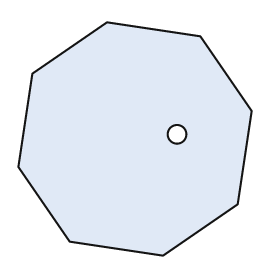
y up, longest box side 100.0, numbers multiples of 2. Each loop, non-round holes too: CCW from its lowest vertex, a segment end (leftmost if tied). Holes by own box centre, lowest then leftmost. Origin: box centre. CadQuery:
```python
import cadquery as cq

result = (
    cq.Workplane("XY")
    .moveTo(12.0, -50.0)
    .lineTo(44.0, -28.0)
    .lineTo(50.0, 12.0)
    .lineTo(28.0, 44.0)
    .lineTo(-12.0, 50.0)
    .lineTo(-44.0, 28.0)
    .lineTo(-50.0, -12.0)
    .lineTo(-28.0, -44.0)
    .close()
    .moveTo(18.0, 2.0)
    .circle(4.0)
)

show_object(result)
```